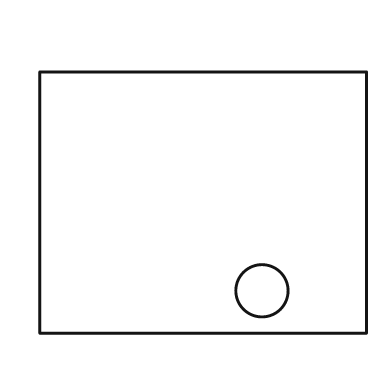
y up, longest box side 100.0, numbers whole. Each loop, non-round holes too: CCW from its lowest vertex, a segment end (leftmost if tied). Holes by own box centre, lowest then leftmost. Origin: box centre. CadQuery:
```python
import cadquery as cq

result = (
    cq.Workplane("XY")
    .moveTo(-50.0, -40.0)
    .lineTo(50.0, -40.0)
    .lineTo(50.0, 40.0)
    .lineTo(-50.0, 40.0)
    .close()
    .moveTo(18.0, -27.0)
    .circle(8.0)
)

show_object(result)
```